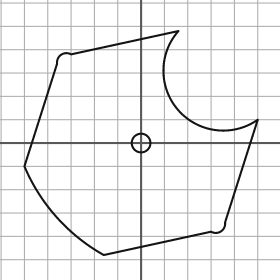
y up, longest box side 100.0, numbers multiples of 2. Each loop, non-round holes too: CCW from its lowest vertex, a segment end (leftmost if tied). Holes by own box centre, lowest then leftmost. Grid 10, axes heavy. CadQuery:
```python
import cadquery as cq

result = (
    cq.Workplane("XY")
    .moveTo(-16.0, -48.0)
    .lineTo(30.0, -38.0)
    .threePointArc((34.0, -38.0), (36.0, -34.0))
    .lineTo(50.0, 10.0)
    .threePointArc((16.0, 14.0), (16.0, 48.0))
    .lineTo(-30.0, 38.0)
    .threePointArc((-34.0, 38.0), (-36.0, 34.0))
    .lineTo(-50.0, -10.0)
    .threePointArc((-36.0, -32.0), (-16.0, -48.0))
    .close()
    .moveTo(0.0, 0.0)
    .circle(4.0)
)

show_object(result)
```